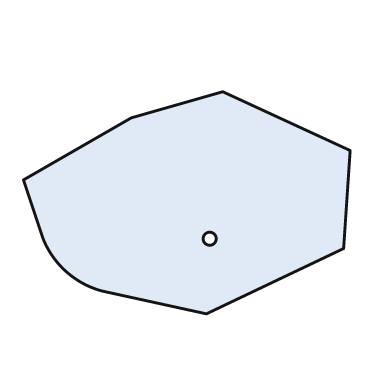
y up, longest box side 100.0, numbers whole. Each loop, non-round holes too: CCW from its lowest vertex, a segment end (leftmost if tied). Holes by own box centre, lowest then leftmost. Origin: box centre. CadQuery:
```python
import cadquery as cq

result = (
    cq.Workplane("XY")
    .moveTo(6.0, -34.0)
    .lineTo(48.0, -14.0)
    .lineTo(50.0, 16.0)
    .lineTo(11.0, 34.0)
    .lineTo(-17.0, 26.0)
    .lineTo(-50.0, 7.0)
    .lineTo(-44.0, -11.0)
    .threePointArc((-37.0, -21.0), (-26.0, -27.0))
    .close()
    .moveTo(7.0, -11.0)
    .circle(2.0)
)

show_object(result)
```